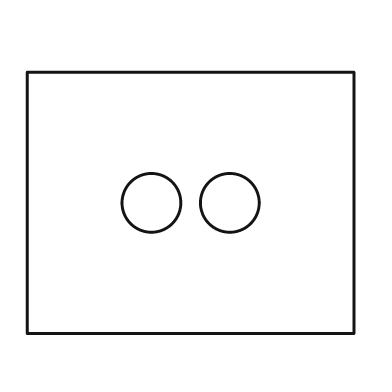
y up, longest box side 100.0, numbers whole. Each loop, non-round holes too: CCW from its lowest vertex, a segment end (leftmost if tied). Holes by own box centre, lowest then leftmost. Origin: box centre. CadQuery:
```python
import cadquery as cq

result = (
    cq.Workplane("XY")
    .moveTo(-50.0, -40.0)
    .lineTo(50.0, -40.0)
    .lineTo(50.0, 40.0)
    .lineTo(-50.0, 40.0)
    .close()
    .moveTo(-12.0, 0.0)
    .circle(9.0)
    .moveTo(12.0, 0.0)
    .circle(9.0)
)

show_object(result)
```